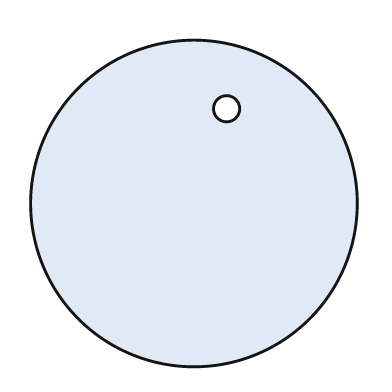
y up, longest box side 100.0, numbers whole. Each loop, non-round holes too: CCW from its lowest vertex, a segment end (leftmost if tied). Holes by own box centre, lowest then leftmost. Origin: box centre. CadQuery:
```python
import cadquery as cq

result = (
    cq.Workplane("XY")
    .moveTo(0.0, 0.0)
    .circle(50.0)
    .moveTo(10.0, 29.0)
    .circle(4.0)
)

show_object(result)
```